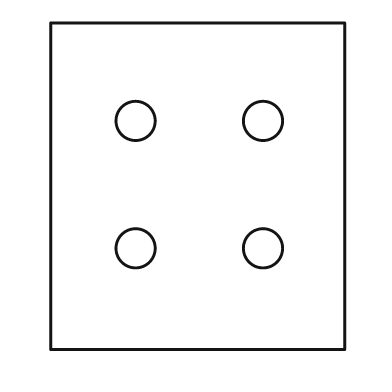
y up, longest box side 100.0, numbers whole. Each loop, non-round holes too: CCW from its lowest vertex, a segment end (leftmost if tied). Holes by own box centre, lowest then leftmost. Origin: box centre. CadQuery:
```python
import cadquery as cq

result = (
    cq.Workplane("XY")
    .moveTo(-45.0, -50.0)
    .lineTo(45.0, -50.0)
    .lineTo(45.0, 50.0)
    .lineTo(-45.0, 50.0)
    .close()
    .moveTo(-19.0, -19.0)
    .circle(6.0)
    .moveTo(20.0, -19.0)
    .circle(6.0)
    .moveTo(-19.0, 20.0)
    .circle(6.0)
    .moveTo(20.0, 20.0)
    .circle(6.0)
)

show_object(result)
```